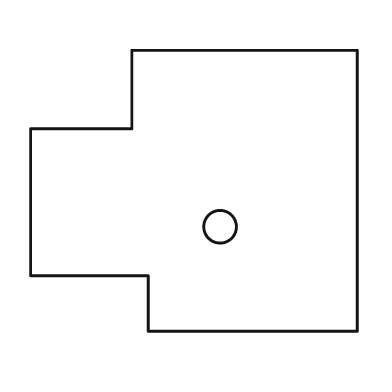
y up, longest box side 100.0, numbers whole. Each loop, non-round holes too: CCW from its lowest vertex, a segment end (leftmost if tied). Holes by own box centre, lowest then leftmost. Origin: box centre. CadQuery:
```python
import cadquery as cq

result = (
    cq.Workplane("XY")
    .moveTo(-14.0, -43.0)
    .lineTo(50.0, -43.0)
    .lineTo(50.0, 43.0)
    .lineTo(-19.0, 43.0)
    .lineTo(-19.0, 19.0)
    .lineTo(-50.0, 19.0)
    .lineTo(-50.0, -26.0)
    .lineTo(-14.0, -26.0)
    .close()
    .moveTo(8.0, -11.0)
    .circle(5.0)
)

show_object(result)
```